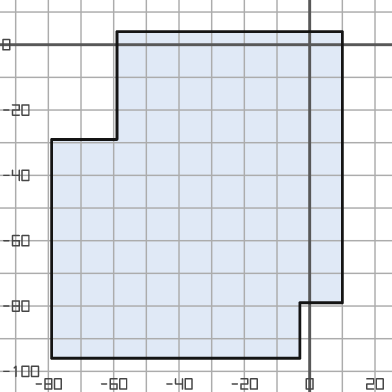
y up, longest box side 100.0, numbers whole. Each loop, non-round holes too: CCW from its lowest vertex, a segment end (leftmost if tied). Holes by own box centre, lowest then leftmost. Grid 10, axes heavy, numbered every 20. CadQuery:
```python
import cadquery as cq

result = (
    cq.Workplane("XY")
    .moveTo(-79.0, -96.0)
    .lineTo(-3.0, -96.0)
    .lineTo(-3.0, -79.0)
    .lineTo(10.0, -79.0)
    .lineTo(10.0, 4.0)
    .lineTo(-59.0, 4.0)
    .lineTo(-59.0, -29.0)
    .lineTo(-79.0, -29.0)
    .close()
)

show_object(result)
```